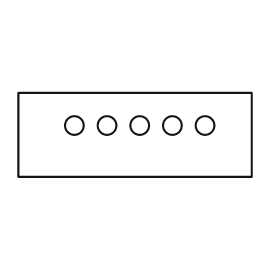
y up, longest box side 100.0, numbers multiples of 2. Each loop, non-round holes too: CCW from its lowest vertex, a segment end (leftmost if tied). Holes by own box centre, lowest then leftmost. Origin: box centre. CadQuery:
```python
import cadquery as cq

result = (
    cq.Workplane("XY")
    .moveTo(-50.0, -18.0)
    .lineTo(50.0, -18.0)
    .lineTo(50.0, 18.0)
    .lineTo(-50.0, 18.0)
    .close()
    .moveTo(-26.0, 4.0)
    .circle(4.0)
    .moveTo(-12.0, 4.0)
    .circle(4.0)
    .moveTo(2.0, 4.0)
    .circle(4.0)
    .moveTo(16.0, 4.0)
    .circle(4.0)
    .moveTo(30.0, 4.0)
    .circle(4.0)
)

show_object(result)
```